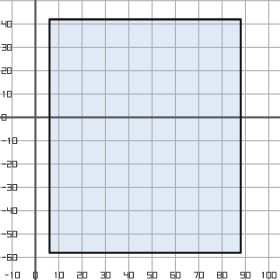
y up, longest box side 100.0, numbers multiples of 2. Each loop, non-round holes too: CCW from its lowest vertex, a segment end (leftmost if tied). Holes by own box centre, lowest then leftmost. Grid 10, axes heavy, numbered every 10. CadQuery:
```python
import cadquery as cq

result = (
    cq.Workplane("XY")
    .moveTo(6.0, -58.0)
    .lineTo(88.0, -58.0)
    .lineTo(88.0, 42.0)
    .lineTo(6.0, 42.0)
    .close()
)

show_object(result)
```